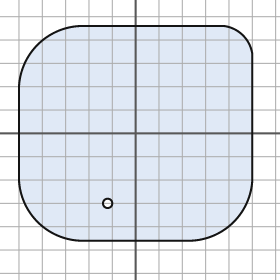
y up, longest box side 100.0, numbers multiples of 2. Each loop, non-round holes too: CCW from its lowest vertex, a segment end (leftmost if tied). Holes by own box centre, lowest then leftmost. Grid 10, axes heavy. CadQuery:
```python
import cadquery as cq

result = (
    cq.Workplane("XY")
    .moveTo(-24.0, -46.0)
    .lineTo(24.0, -46.0)
    .threePointArc((42.0, -38.0), (50.0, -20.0))
    .lineTo(50.0, 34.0)
    .threePointArc((46.0, 42.0), (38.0, 46.0))
    .lineTo(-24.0, 46.0)
    .threePointArc((-42.0, 38.0), (-50.0, 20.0))
    .lineTo(-50.0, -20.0)
    .threePointArc((-42.0, -38.0), (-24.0, -46.0))
    .close()
    .moveTo(-12.0, -30.0)
    .circle(2.0)
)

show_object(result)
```